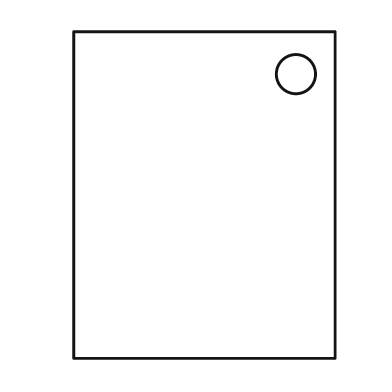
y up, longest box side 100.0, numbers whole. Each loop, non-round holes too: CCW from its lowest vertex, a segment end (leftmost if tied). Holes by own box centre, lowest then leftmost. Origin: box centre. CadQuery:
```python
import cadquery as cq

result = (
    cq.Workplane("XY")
    .moveTo(-40.0, -50.0)
    .lineTo(40.0, -50.0)
    .lineTo(40.0, 50.0)
    .lineTo(-40.0, 50.0)
    .close()
    .moveTo(28.0, 37.0)
    .circle(6.0)
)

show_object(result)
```